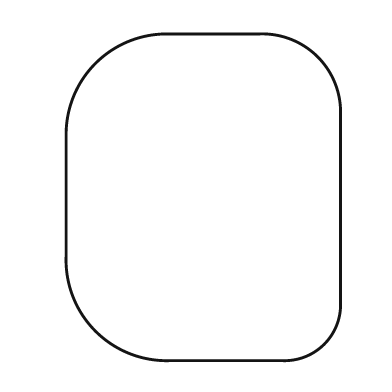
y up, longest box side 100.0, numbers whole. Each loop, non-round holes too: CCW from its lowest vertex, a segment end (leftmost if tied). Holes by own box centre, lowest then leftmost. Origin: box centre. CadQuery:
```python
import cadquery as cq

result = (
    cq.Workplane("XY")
    .moveTo(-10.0, -50.0)
    .lineTo(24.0, -50.0)
    .threePointArc((37.0, -45.0), (42.0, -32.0))
    .lineTo(42.0, 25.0)
    .threePointArc((35.0, 43.0), (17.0, 50.0))
    .lineTo(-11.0, 50.0)
    .threePointArc((-33.0, 41.0), (-42.0, 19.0))
    .lineTo(-42.0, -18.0)
    .threePointArc((-33.0, -41.0), (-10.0, -50.0))
    .close()
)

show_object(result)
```